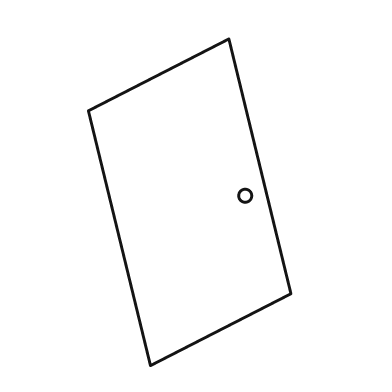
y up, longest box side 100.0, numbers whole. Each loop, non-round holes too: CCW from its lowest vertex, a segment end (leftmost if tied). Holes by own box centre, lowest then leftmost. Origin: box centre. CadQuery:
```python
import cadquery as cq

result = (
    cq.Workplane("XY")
    .moveTo(-12.0, -50.0)
    .lineTo(31.0, -28.0)
    .lineTo(12.0, 50.0)
    .lineTo(-31.0, 28.0)
    .close()
    .moveTo(17.0, 2.0)
    .circle(2.0)
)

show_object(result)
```